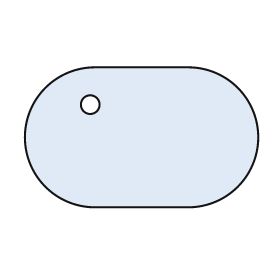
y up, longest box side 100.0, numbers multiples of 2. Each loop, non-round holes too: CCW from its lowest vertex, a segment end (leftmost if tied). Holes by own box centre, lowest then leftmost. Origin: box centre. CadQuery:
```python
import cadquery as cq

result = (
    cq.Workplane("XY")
    .moveTo(-20.0, -30.0)
    .lineTo(20.0, -30.0)
    .threePointArc((50.0, 0.0), (20.0, 30.0))
    .lineTo(-20.0, 30.0)
    .threePointArc((-50.0, 0.0), (-20.0, -30.0))
    .close()
    .moveTo(-22.0, 14.0)
    .circle(4.0)
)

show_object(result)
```